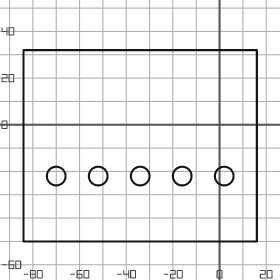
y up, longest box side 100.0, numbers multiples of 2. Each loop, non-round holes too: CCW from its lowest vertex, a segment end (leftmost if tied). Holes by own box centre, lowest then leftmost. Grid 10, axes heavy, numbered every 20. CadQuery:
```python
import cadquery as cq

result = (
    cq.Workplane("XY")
    .moveTo(-84.0, -50.0)
    .lineTo(16.0, -50.0)
    .lineTo(16.0, 32.0)
    .lineTo(-84.0, 32.0)
    .close()
    .moveTo(-70.0, -22.0)
    .circle(4.0)
    .moveTo(-52.0, -22.0)
    .circle(4.0)
    .moveTo(-34.0, -22.0)
    .circle(4.0)
    .moveTo(-16.0, -22.0)
    .circle(4.0)
    .moveTo(2.0, -22.0)
    .circle(4.0)
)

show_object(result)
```